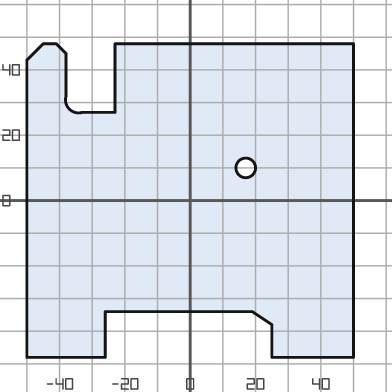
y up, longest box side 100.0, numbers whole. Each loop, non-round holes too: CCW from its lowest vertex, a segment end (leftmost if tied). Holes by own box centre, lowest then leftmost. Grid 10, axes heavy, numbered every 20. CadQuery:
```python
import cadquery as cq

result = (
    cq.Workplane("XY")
    .moveTo(-50.0, -48.0)
    .lineTo(-26.0, -48.0)
    .lineTo(-26.0, -34.0)
    .lineTo(19.0, -34.0)
    .lineTo(25.0, -38.0)
    .lineTo(25.0, -48.0)
    .lineTo(50.0, -48.0)
    .lineTo(50.0, 48.0)
    .lineTo(-23.0, 48.0)
    .lineTo(-23.0, 27.0)
    .lineTo(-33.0, 27.0)
    .threePointArc((-37.0, 28.0), (-38.0, 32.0))
    .lineTo(-38.0, 45.0)
    .lineTo(-41.0, 48.0)
    .lineTo(-45.0, 48.0)
    .lineTo(-50.0, 43.0)
    .close()
    .moveTo(17.0, 10.0)
    .circle(3.0)
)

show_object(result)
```